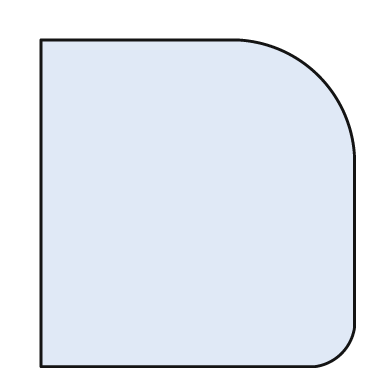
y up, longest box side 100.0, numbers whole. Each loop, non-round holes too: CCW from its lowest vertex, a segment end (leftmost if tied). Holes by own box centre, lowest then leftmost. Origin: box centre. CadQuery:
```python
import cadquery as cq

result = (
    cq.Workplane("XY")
    .moveTo(-48.0, -50.0)
    .lineTo(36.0, -50.0)
    .threePointArc((44.0, -46.0), (48.0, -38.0))
    .lineTo(48.0, 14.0)
    .threePointArc((37.0, 39.0), (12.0, 50.0))
    .lineTo(-48.0, 50.0)
    .close()
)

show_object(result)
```